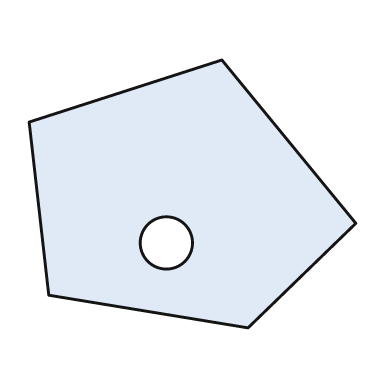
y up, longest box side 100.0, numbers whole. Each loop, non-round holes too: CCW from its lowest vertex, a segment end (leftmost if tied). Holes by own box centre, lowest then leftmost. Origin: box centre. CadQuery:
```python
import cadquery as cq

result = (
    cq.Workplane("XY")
    .moveTo(17.0, -41.0)
    .lineTo(50.0, -9.0)
    .lineTo(9.0, 41.0)
    .lineTo(-50.0, 22.0)
    .lineTo(-44.0, -31.0)
    .close()
    .moveTo(-8.0, -15.0)
    .circle(8.0)
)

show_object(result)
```